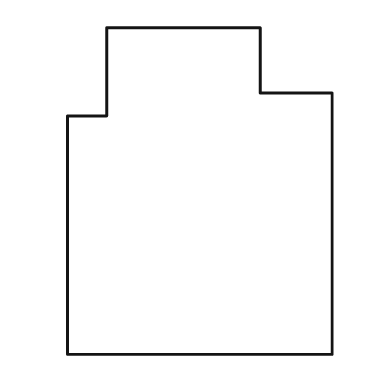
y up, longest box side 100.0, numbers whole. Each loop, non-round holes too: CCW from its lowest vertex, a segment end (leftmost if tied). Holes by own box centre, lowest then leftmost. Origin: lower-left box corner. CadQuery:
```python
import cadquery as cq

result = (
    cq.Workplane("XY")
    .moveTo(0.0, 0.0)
    .lineTo(81.0, 0.0)
    .lineTo(81.0, 80.0)
    .lineTo(59.0, 80.0)
    .lineTo(59.0, 100.0)
    .lineTo(12.0, 100.0)
    .lineTo(12.0, 73.0)
    .lineTo(0.0, 73.0)
    .close()
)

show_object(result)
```